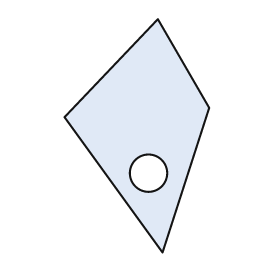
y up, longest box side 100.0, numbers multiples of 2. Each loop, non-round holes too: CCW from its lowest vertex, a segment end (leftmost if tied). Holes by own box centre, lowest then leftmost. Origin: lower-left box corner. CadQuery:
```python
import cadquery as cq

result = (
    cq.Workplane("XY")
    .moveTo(42.0, 0.0)
    .lineTo(62.0, 62.0)
    .lineTo(40.0, 100.0)
    .lineTo(0.0, 58.0)
    .close()
    .moveTo(36.0, 34.0)
    .circle(8.0)
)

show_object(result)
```